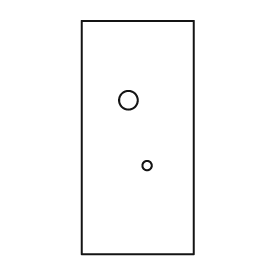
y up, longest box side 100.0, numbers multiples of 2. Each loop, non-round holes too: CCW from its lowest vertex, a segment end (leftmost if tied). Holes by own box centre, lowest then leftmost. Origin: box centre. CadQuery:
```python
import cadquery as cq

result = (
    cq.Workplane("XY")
    .moveTo(-24.0, -50.0)
    .lineTo(24.0, -50.0)
    .lineTo(24.0, 50.0)
    .lineTo(-24.0, 50.0)
    .close()
    .moveTo(4.0, -12.0)
    .circle(2.0)
    .moveTo(-4.0, 16.0)
    .circle(4.0)
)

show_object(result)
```